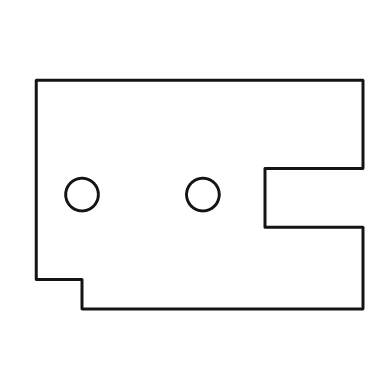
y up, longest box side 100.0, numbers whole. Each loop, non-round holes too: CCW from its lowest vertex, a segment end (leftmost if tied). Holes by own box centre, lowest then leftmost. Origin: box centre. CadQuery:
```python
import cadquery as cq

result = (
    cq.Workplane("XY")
    .moveTo(-36.0, -35.0)
    .lineTo(50.0, -35.0)
    .lineTo(50.0, -10.0)
    .lineTo(20.0, -10.0)
    .lineTo(20.0, 8.0)
    .lineTo(50.0, 8.0)
    .lineTo(50.0, 35.0)
    .lineTo(-50.0, 35.0)
    .lineTo(-50.0, -26.0)
    .lineTo(-36.0, -26.0)
    .close()
    .moveTo(-36.0, 0.0)
    .circle(5.0)
    .moveTo(1.0, 0.0)
    .circle(5.0)
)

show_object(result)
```